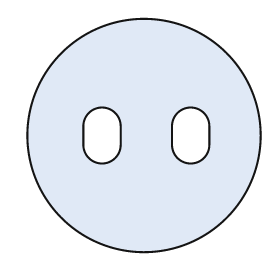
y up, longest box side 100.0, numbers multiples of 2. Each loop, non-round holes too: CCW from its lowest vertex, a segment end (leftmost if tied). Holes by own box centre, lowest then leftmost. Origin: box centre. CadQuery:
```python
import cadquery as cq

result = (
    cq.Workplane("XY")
    .moveTo(0.0, 0.0)
    .circle(50.0)
    .moveTo(-26.0, -4.0)
    .threePointArc((-18.0, -12.0), (-10.0, -4.0))
    .lineTo(-10.0, 4.0)
    .threePointArc((-18.0, 12.0), (-26.0, 4.0))
    .close()
    .moveTo(12.0, -4.0)
    .threePointArc((20.0, -12.0), (28.0, -4.0))
    .lineTo(28.0, 4.0)
    .threePointArc((20.0, 12.0), (12.0, 4.0))
    .close()
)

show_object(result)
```